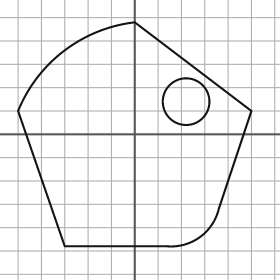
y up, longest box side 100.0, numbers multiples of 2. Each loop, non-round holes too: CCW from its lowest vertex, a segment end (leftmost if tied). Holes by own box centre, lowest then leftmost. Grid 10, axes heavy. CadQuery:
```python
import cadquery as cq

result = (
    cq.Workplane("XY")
    .moveTo(-30.0, -48.0)
    .lineTo(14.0, -48.0)
    .threePointArc((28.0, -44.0), (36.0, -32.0))
    .lineTo(50.0, 10.0)
    .lineTo(0.0, 48.0)
    .threePointArc((-30.0, 36.0), (-50.0, 10.0))
    .close()
    .moveTo(22.0, 14.0)
    .circle(10.0)
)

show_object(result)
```